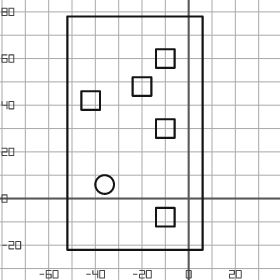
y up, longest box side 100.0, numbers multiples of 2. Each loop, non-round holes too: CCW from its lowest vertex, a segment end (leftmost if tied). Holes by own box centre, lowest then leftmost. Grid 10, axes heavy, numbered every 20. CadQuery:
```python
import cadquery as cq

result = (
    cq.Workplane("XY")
    .moveTo(-52.0, -22.0)
    .lineTo(6.0, -22.0)
    .lineTo(6.0, 78.0)
    .lineTo(-52.0, 78.0)
    .close()
    .moveTo(-14.0, -12.0)
    .lineTo(-6.0, -12.0)
    .lineTo(-6.0, -4.0)
    .lineTo(-14.0, -4.0)
    .close()
    .moveTo(-36.0, 6.0)
    .circle(4.0)
    .moveTo(-14.0, 26.0)
    .lineTo(-6.0, 26.0)
    .lineTo(-6.0, 34.0)
    .lineTo(-14.0, 34.0)
    .close()
    .moveTo(-46.0, 38.0)
    .lineTo(-38.0, 38.0)
    .lineTo(-38.0, 46.0)
    .lineTo(-46.0, 46.0)
    .close()
    .moveTo(-24.0, 44.0)
    .lineTo(-16.0, 44.0)
    .lineTo(-16.0, 52.0)
    .lineTo(-24.0, 52.0)
    .close()
    .moveTo(-14.0, 56.0)
    .lineTo(-6.0, 56.0)
    .lineTo(-6.0, 64.0)
    .lineTo(-14.0, 64.0)
    .close()
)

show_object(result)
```